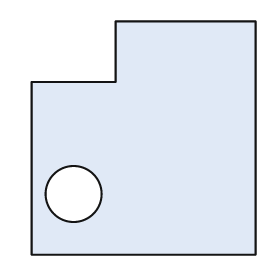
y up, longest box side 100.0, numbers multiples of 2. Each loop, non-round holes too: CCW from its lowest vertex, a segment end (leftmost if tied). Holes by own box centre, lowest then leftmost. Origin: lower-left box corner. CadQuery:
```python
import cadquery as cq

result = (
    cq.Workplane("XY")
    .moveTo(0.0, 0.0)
    .lineTo(96.0, 0.0)
    .lineTo(96.0, 100.0)
    .lineTo(36.0, 100.0)
    .lineTo(36.0, 74.0)
    .lineTo(0.0, 74.0)
    .close()
    .moveTo(18.0, 26.0)
    .circle(12.0)
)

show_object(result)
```